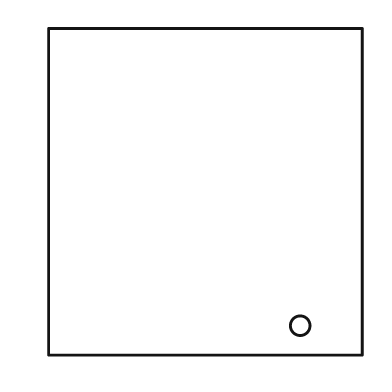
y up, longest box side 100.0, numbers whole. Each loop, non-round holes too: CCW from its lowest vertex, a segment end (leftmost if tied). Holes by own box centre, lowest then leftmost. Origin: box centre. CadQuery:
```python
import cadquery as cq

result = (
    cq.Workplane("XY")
    .moveTo(-48.0, -50.0)
    .lineTo(48.0, -50.0)
    .lineTo(48.0, 50.0)
    .lineTo(-48.0, 50.0)
    .close()
    .moveTo(29.0, -41.0)
    .circle(3.0)
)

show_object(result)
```